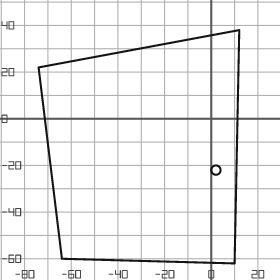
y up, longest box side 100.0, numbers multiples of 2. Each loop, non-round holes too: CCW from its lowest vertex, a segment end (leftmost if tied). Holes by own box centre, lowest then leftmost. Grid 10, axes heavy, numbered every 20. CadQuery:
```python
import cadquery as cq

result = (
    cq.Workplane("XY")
    .moveTo(10.0, -62.0)
    .lineTo(12.0, 38.0)
    .lineTo(-74.0, 22.0)
    .lineTo(-64.0, -60.0)
    .close()
    .moveTo(2.0, -22.0)
    .circle(2.0)
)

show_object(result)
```